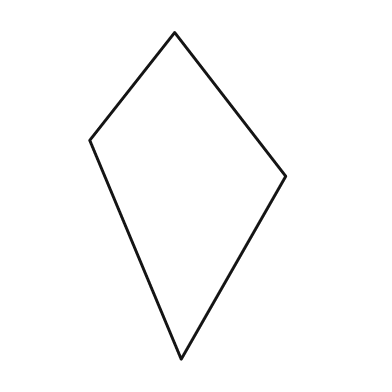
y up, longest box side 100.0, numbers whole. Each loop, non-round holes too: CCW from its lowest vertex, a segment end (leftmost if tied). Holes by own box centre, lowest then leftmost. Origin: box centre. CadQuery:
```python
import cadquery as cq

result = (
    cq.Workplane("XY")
    .moveTo(-2.0, -50.0)
    .lineTo(30.0, 6.0)
    .lineTo(-4.0, 50.0)
    .lineTo(-30.0, 17.0)
    .close()
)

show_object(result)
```